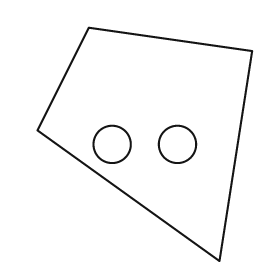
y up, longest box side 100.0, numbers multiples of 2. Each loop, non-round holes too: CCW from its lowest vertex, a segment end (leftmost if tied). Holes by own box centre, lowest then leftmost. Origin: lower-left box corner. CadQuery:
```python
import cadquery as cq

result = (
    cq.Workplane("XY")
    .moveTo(78.0, 0.0)
    .lineTo(92.0, 90.0)
    .lineTo(22.0, 100.0)
    .lineTo(0.0, 56.0)
    .close()
    .moveTo(32.0, 50.0)
    .circle(8.0)
    .moveTo(60.0, 50.0)
    .circle(8.0)
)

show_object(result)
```